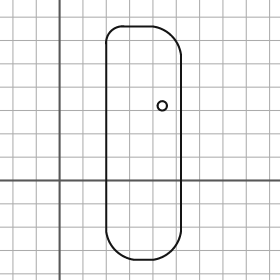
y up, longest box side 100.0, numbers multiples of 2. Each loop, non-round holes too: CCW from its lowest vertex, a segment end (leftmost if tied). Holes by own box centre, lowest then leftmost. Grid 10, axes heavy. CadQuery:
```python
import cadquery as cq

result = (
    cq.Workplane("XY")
    .moveTo(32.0, -34.0)
    .lineTo(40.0, -34.0)
    .threePointArc((48.0, -30.0), (52.0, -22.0))
    .lineTo(52.0, 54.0)
    .threePointArc((48.0, 62.0), (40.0, 66.0))
    .lineTo(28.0, 66.0)
    .threePointArc((22.0, 64.0), (20.0, 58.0))
    .lineTo(20.0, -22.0)
    .threePointArc((24.0, -30.0), (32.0, -34.0))
    .close()
    .moveTo(44.0, 32.0)
    .circle(2.0)
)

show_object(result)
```